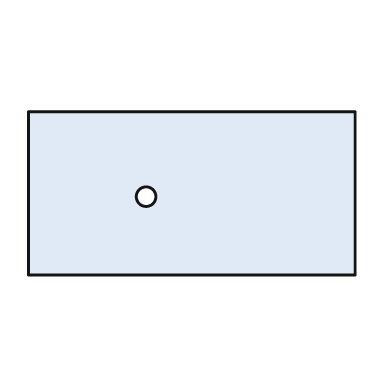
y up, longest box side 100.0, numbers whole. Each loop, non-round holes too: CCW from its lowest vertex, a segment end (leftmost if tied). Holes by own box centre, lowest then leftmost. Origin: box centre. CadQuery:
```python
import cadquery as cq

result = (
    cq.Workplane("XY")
    .moveTo(-50.0, -25.0)
    .lineTo(50.0, -25.0)
    .lineTo(50.0, 25.0)
    .lineTo(-50.0, 25.0)
    .close()
    .moveTo(-14.0, -1.0)
    .circle(3.0)
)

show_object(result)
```